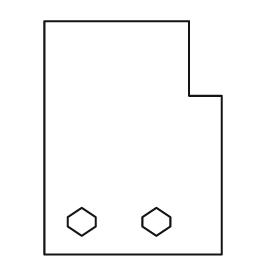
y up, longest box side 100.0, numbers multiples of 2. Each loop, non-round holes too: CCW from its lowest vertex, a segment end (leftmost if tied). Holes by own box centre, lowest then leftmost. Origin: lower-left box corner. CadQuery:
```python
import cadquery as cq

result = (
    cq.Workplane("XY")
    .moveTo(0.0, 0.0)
    .lineTo(76.0, 0.0)
    .lineTo(76.0, 68.0)
    .lineTo(62.0, 68.0)
    .lineTo(62.0, 100.0)
    .lineTo(0.0, 100.0)
    .close()
    .moveTo(16.0, 8.0)
    .lineTo(22.0, 12.0)
    .lineTo(22.0, 16.0)
    .lineTo(16.0, 20.0)
    .lineTo(10.0, 16.0)
    .lineTo(10.0, 12.0)
    .close()
    .moveTo(48.0, 8.0)
    .lineTo(54.0, 12.0)
    .lineTo(54.0, 16.0)
    .lineTo(48.0, 20.0)
    .lineTo(42.0, 16.0)
    .lineTo(42.0, 12.0)
    .close()
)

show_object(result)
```